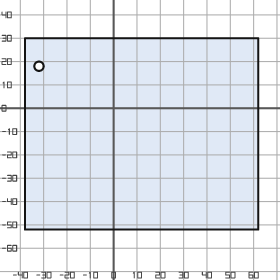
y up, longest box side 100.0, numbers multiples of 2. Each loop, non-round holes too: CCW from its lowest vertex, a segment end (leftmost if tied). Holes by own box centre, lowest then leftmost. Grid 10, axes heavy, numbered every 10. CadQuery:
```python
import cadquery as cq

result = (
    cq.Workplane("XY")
    .moveTo(-38.0, -52.0)
    .lineTo(62.0, -52.0)
    .lineTo(62.0, 30.0)
    .lineTo(-38.0, 30.0)
    .close()
    .moveTo(-32.0, 18.0)
    .circle(2.0)
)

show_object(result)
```